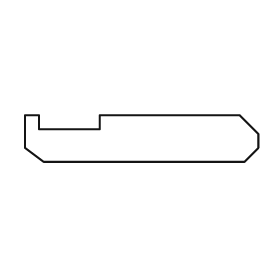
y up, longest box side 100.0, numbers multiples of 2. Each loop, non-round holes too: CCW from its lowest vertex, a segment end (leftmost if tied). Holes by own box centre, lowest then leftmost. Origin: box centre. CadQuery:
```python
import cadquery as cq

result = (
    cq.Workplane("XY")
    .moveTo(-42.0, -10.0)
    .lineTo(44.0, -10.0)
    .lineTo(50.0, -4.0)
    .lineTo(50.0, 2.0)
    .lineTo(42.0, 10.0)
    .lineTo(-18.0, 10.0)
    .lineTo(-18.0, 4.0)
    .lineTo(-44.0, 4.0)
    .lineTo(-44.0, 10.0)
    .lineTo(-50.0, 10.0)
    .lineTo(-50.0, -4.0)
    .close()
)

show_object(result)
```